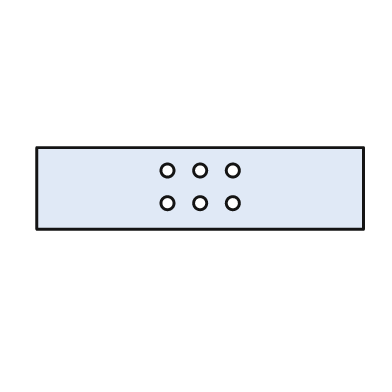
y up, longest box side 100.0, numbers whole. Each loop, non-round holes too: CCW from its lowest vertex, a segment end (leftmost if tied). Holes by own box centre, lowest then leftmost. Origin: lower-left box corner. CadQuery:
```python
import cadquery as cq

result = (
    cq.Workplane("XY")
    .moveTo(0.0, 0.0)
    .lineTo(100.0, 0.0)
    .lineTo(100.0, 25.0)
    .lineTo(0.0, 25.0)
    .close()
    .moveTo(40.0, 8.0)
    .circle(2.0)
    .moveTo(50.0, 8.0)
    .circle(2.0)
    .moveTo(60.0, 8.0)
    .circle(2.0)
    .moveTo(40.0, 18.0)
    .circle(2.0)
    .moveTo(50.0, 18.0)
    .circle(2.0)
    .moveTo(60.0, 18.0)
    .circle(2.0)
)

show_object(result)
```